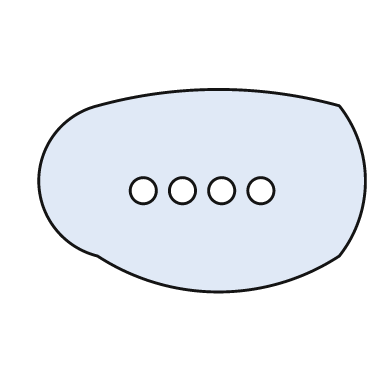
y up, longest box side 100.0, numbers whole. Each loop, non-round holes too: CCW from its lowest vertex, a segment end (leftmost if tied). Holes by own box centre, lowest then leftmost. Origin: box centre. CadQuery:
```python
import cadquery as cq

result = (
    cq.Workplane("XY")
    .moveTo(-32.0, -20.0)
    .threePointArc((5.0, -31.0), (42.0, -20.0))
    .threePointArc((50.0, 3.0), (42.0, 26.0))
    .threePointArc((5.0, 31.0), (-32.0, 26.0))
    .threePointArc((-50.0, 3.0), (-32.0, -20.0))
    .close()
    .moveTo(-18.0, 0.0)
    .circle(4.0)
    .moveTo(-6.0, 0.0)
    .circle(4.0)
    .moveTo(6.0, 0.0)
    .circle(4.0)
    .moveTo(18.0, 0.0)
    .circle(4.0)
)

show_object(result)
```